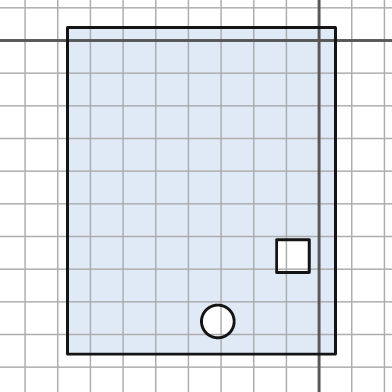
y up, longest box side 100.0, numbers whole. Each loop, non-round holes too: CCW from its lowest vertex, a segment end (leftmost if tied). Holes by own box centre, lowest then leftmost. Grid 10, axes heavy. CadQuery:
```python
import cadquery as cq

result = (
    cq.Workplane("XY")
    .moveTo(-77.0, -96.0)
    .lineTo(5.0, -96.0)
    .lineTo(5.0, 4.0)
    .lineTo(-77.0, 4.0)
    .close()
    .moveTo(-31.0, -86.0)
    .circle(5.0)
    .moveTo(-13.0, -71.0)
    .lineTo(-3.0, -71.0)
    .lineTo(-3.0, -61.0)
    .lineTo(-13.0, -61.0)
    .close()
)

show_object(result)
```